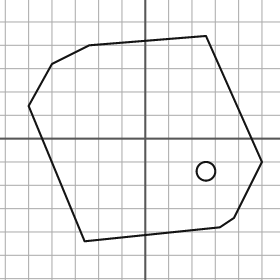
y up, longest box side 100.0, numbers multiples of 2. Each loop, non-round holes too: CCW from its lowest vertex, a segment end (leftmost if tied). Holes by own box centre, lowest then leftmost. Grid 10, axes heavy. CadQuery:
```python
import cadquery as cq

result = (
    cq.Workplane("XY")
    .moveTo(-26.0, -44.0)
    .lineTo(32.0, -38.0)
    .lineTo(38.0, -34.0)
    .lineTo(50.0, -10.0)
    .lineTo(26.0, 44.0)
    .lineTo(-24.0, 40.0)
    .lineTo(-40.0, 32.0)
    .lineTo(-50.0, 14.0)
    .close()
    .moveTo(26.0, -14.0)
    .circle(4.0)
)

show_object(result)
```